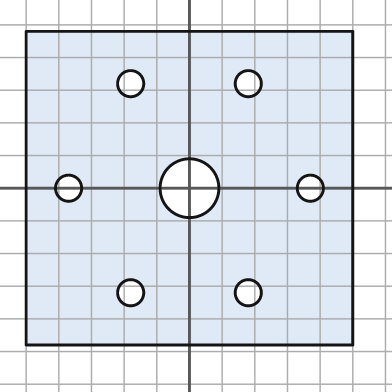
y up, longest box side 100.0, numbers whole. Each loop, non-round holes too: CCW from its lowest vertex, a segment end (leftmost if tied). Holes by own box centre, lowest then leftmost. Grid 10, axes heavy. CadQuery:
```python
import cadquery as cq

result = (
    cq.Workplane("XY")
    .moveTo(-50.0, -48.0)
    .lineTo(50.0, -48.0)
    .lineTo(50.0, 48.0)
    .lineTo(-50.0, 48.0)
    .close()
    .moveTo(-18.0, -32.0)
    .circle(4.0)
    .moveTo(18.0, -32.0)
    .circle(4.0)
    .moveTo(-37.0, 0.0)
    .circle(4.0)
    .moveTo(0.0, 0.0)
    .circle(9.0)
    .moveTo(37.0, 0.0)
    .circle(4.0)
    .moveTo(-18.0, 32.0)
    .circle(4.0)
    .moveTo(18.0, 32.0)
    .circle(4.0)
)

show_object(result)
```